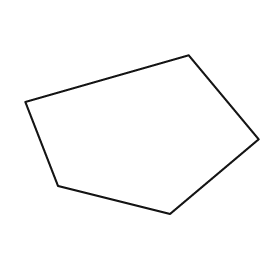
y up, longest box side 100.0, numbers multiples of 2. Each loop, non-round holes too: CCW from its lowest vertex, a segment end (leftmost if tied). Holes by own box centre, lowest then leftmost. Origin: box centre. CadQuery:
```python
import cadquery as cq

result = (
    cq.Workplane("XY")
    .moveTo(12.0, -34.0)
    .lineTo(50.0, -2.0)
    .lineTo(20.0, 34.0)
    .lineTo(-50.0, 14.0)
    .lineTo(-36.0, -22.0)
    .close()
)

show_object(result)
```